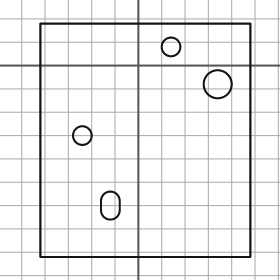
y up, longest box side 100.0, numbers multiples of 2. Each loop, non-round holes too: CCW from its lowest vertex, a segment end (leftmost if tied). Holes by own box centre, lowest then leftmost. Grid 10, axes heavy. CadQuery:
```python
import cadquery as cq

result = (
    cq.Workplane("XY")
    .moveTo(-42.0, -82.0)
    .lineTo(48.0, -82.0)
    .lineTo(48.0, 18.0)
    .lineTo(-42.0, 18.0)
    .close()
    .moveTo(-16.0, -62.0)
    .threePointArc((-12.0, -66.0), (-8.0, -62.0))
    .lineTo(-8.0, -58.0)
    .threePointArc((-12.0, -54.0), (-16.0, -58.0))
    .close()
    .moveTo(-24.0, -30.0)
    .circle(4.0)
    .moveTo(34.0, -8.0)
    .circle(6.0)
    .moveTo(14.0, 8.0)
    .circle(4.0)
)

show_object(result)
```